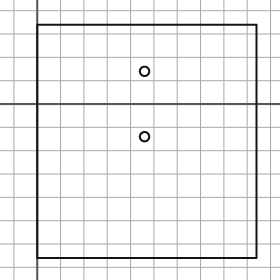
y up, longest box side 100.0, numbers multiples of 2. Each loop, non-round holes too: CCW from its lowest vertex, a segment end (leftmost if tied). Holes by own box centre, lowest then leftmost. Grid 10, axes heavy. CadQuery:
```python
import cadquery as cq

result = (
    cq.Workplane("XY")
    .moveTo(0.0, -66.0)
    .lineTo(94.0, -66.0)
    .lineTo(94.0, 34.0)
    .lineTo(0.0, 34.0)
    .close()
    .moveTo(46.0, -14.0)
    .circle(2.0)
    .moveTo(46.0, 14.0)
    .circle(2.0)
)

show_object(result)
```